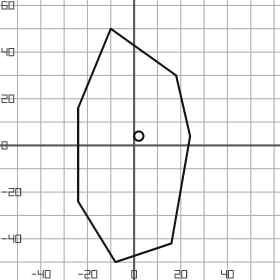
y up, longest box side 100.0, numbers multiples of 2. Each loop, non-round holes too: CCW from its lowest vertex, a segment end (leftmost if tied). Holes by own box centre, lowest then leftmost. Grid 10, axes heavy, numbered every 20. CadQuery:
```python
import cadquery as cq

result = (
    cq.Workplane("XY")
    .moveTo(-8.0, -50.0)
    .lineTo(16.0, -42.0)
    .lineTo(24.0, 4.0)
    .lineTo(18.0, 30.0)
    .lineTo(-10.0, 50.0)
    .lineTo(-24.0, 16.0)
    .lineTo(-24.0, -24.0)
    .close()
    .moveTo(2.0, 4.0)
    .circle(2.0)
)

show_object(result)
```